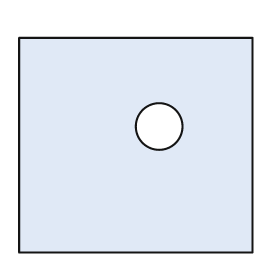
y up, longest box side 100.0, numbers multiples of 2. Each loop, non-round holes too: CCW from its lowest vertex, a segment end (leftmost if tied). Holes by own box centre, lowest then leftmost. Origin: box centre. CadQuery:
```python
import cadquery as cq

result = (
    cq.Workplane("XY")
    .moveTo(-50.0, -46.0)
    .lineTo(50.0, -46.0)
    .lineTo(50.0, 46.0)
    .lineTo(-50.0, 46.0)
    .close()
    .moveTo(10.0, 8.0)
    .circle(10.0)
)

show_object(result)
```